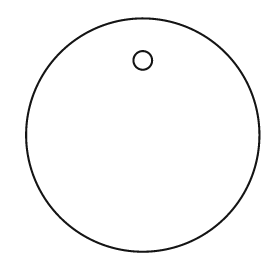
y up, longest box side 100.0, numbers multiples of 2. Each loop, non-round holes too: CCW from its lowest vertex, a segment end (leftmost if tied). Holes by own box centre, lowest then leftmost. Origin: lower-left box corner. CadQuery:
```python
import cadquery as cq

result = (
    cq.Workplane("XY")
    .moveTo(50.0, 50.0)
    .circle(50.0)
    .moveTo(50.0, 82.0)
    .circle(4.0)
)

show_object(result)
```